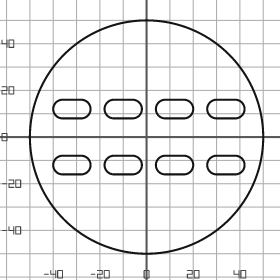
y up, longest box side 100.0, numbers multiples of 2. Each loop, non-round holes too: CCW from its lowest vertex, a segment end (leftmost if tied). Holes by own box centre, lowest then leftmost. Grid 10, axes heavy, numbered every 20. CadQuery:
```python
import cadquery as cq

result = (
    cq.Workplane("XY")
    .moveTo(0.0, 0.0)
    .circle(50.0)
    .moveTo(-36.0, -16.0)
    .lineTo(-28.0, -16.0)
    .threePointArc((-24.0, -12.0), (-28.0, -8.0))
    .lineTo(-36.0, -8.0)
    .threePointArc((-40.0, -12.0), (-36.0, -16.0))
    .close()
    .moveTo(-14.0, -16.0)
    .lineTo(-6.0, -16.0)
    .threePointArc((-2.0, -12.0), (-6.0, -8.0))
    .lineTo(-14.0, -8.0)
    .threePointArc((-18.0, -12.0), (-14.0, -16.0))
    .close()
    .moveTo(8.0, -16.0)
    .lineTo(16.0, -16.0)
    .threePointArc((20.0, -12.0), (16.0, -8.0))
    .lineTo(8.0, -8.0)
    .threePointArc((4.0, -12.0), (8.0, -16.0))
    .close()
    .moveTo(30.0, -16.0)
    .lineTo(38.0, -16.0)
    .threePointArc((42.0, -12.0), (38.0, -8.0))
    .lineTo(30.0, -8.0)
    .threePointArc((26.0, -12.0), (30.0, -16.0))
    .close()
    .moveTo(-36.0, 8.0)
    .lineTo(-28.0, 8.0)
    .threePointArc((-24.0, 12.0), (-28.0, 16.0))
    .lineTo(-36.0, 16.0)
    .threePointArc((-40.0, 12.0), (-36.0, 8.0))
    .close()
    .moveTo(-14.0, 8.0)
    .lineTo(-6.0, 8.0)
    .threePointArc((-2.0, 12.0), (-6.0, 16.0))
    .lineTo(-14.0, 16.0)
    .threePointArc((-18.0, 12.0), (-14.0, 8.0))
    .close()
    .moveTo(8.0, 8.0)
    .lineTo(16.0, 8.0)
    .threePointArc((20.0, 12.0), (16.0, 16.0))
    .lineTo(8.0, 16.0)
    .threePointArc((4.0, 12.0), (8.0, 8.0))
    .close()
    .moveTo(30.0, 8.0)
    .lineTo(38.0, 8.0)
    .threePointArc((42.0, 12.0), (38.0, 16.0))
    .lineTo(30.0, 16.0)
    .threePointArc((26.0, 12.0), (30.0, 8.0))
    .close()
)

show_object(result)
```